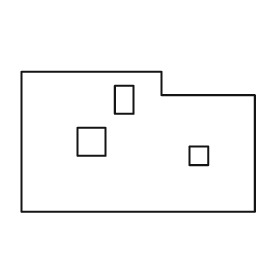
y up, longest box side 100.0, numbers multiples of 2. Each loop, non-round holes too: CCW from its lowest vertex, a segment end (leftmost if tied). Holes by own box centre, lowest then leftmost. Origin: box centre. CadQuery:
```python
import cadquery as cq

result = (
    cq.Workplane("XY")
    .moveTo(-50.0, -30.0)
    .lineTo(50.0, -30.0)
    .lineTo(50.0, 20.0)
    .lineTo(10.0, 20.0)
    .lineTo(10.0, 30.0)
    .lineTo(-50.0, 30.0)
    .close()
    .moveTo(22.0, -10.0)
    .lineTo(30.0, -10.0)
    .lineTo(30.0, -2.0)
    .lineTo(22.0, -2.0)
    .close()
    .moveTo(-26.0, -6.0)
    .lineTo(-14.0, -6.0)
    .lineTo(-14.0, 6.0)
    .lineTo(-26.0, 6.0)
    .close()
    .moveTo(-10.0, 12.0)
    .lineTo(-2.0, 12.0)
    .lineTo(-2.0, 24.0)
    .lineTo(-10.0, 24.0)
    .close()
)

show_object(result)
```